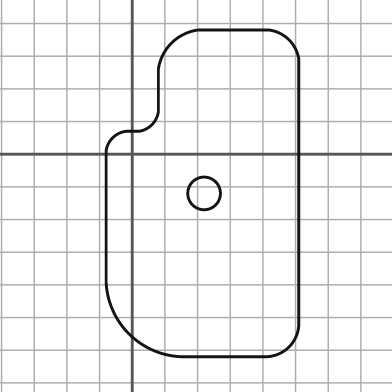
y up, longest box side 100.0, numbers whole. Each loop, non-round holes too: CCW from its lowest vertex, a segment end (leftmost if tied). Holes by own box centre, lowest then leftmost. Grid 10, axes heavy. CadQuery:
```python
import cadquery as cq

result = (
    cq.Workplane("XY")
    .moveTo(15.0, -62.0)
    .lineTo(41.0, -62.0)
    .threePointArc((48.0, -59.0), (51.0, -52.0))
    .lineTo(51.0, 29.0)
    .threePointArc((48.0, 35.0), (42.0, 38.0))
    .lineTo(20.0, 38.0)
    .threePointArc((12.0, 34.0), (8.0, 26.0))
    .lineTo(8.0, 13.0)
    .threePointArc((6.0, 9.0), (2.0, 7.0))
    .lineTo(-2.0, 7.0)
    .threePointArc((-6.0, 5.0), (-8.0, 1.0))
    .lineTo(-8.0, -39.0)
    .threePointArc((-1.0, -55.0), (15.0, -62.0))
    .close()
    .moveTo(22.0, -12.0)
    .circle(5.0)
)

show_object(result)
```